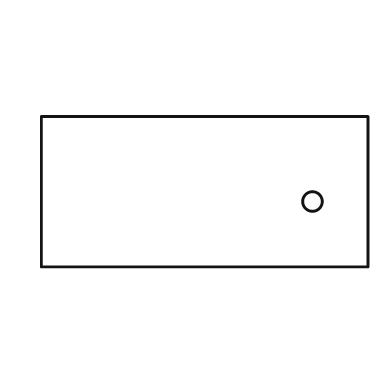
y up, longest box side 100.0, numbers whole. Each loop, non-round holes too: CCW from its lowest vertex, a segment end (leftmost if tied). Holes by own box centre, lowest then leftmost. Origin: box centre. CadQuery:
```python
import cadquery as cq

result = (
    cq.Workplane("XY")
    .moveTo(-50.0, -23.0)
    .lineTo(50.0, -23.0)
    .lineTo(50.0, 23.0)
    .lineTo(-50.0, 23.0)
    .close()
    .moveTo(33.0, -3.0)
    .circle(3.0)
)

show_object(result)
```